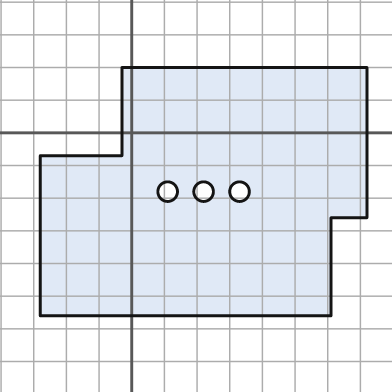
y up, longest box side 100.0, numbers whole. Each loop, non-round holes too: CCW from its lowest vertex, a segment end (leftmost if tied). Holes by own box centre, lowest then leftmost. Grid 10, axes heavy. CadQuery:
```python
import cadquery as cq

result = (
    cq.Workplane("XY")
    .moveTo(-28.0, -56.0)
    .lineTo(61.0, -56.0)
    .lineTo(61.0, -26.0)
    .lineTo(72.0, -26.0)
    .lineTo(72.0, 20.0)
    .lineTo(-3.0, 20.0)
    .lineTo(-3.0, -7.0)
    .lineTo(-28.0, -7.0)
    .close()
    .moveTo(11.0, -18.0)
    .circle(3.0)
    .moveTo(22.0, -18.0)
    .circle(3.0)
    .moveTo(33.0, -18.0)
    .circle(3.0)
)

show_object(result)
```